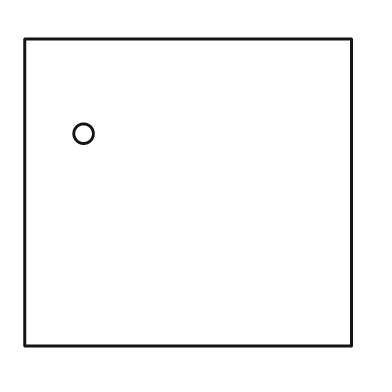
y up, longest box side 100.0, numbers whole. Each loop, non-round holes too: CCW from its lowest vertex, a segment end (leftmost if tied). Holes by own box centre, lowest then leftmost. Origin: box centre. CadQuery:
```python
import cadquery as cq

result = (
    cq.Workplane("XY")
    .moveTo(-50.0, -47.0)
    .lineTo(50.0, -47.0)
    .lineTo(50.0, 47.0)
    .lineTo(-50.0, 47.0)
    .close()
    .moveTo(-32.0, 18.0)
    .circle(3.0)
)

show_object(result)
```